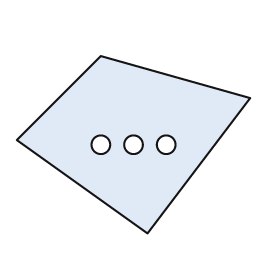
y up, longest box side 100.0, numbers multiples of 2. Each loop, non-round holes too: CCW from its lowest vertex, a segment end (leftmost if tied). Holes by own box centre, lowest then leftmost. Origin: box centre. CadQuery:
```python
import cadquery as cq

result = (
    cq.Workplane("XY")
    .moveTo(6.0, -38.0)
    .lineTo(50.0, 20.0)
    .lineTo(-14.0, 38.0)
    .lineTo(-50.0, 2.0)
    .close()
    .moveTo(-14.0, 0.0)
    .circle(4.0)
    .moveTo(0.0, 0.0)
    .circle(4.0)
    .moveTo(14.0, 0.0)
    .circle(4.0)
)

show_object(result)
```